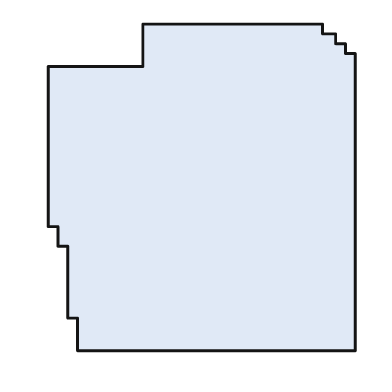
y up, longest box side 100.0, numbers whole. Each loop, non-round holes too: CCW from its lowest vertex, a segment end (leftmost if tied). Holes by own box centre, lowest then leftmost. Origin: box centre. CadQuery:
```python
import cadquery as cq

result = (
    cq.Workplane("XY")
    .moveTo(-38.0, -50.0)
    .lineTo(47.0, -50.0)
    .lineTo(47.0, 41.0)
    .lineTo(44.0, 41.0)
    .lineTo(44.0, 44.0)
    .lineTo(41.0, 44.0)
    .lineTo(41.0, 47.0)
    .lineTo(37.0, 47.0)
    .lineTo(37.0, 50.0)
    .lineTo(-18.0, 50.0)
    .lineTo(-18.0, 37.0)
    .lineTo(-47.0, 37.0)
    .lineTo(-47.0, -12.0)
    .lineTo(-44.0, -12.0)
    .lineTo(-44.0, -18.0)
    .lineTo(-41.0, -18.0)
    .lineTo(-41.0, -40.0)
    .lineTo(-38.0, -40.0)
    .close()
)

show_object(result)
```